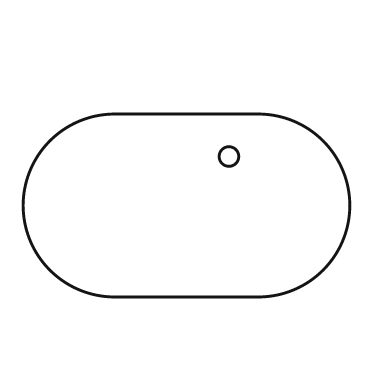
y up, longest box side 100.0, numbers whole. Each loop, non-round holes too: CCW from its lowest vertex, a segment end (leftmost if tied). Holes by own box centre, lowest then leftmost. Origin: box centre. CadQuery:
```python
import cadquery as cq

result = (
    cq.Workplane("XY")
    .moveTo(-22.0, -28.0)
    .lineTo(22.0, -28.0)
    .threePointArc((50.0, 0.0), (22.0, 28.0))
    .lineTo(-22.0, 28.0)
    .threePointArc((-50.0, 0.0), (-22.0, -28.0))
    .close()
    .moveTo(13.0, 15.0)
    .circle(3.0)
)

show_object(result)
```